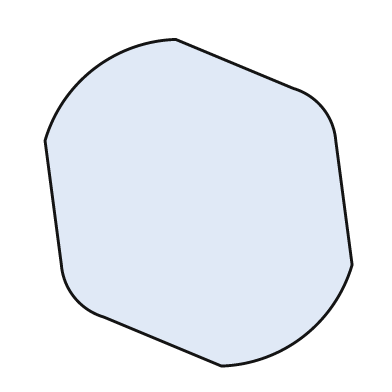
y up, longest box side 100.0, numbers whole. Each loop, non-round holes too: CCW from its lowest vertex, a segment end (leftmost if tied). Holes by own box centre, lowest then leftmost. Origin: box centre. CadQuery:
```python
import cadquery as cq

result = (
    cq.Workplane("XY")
    .moveTo(7.0, -50.0)
    .threePointArc((32.0, -41.0), (47.0, -19.0))
    .lineTo(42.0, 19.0)
    .threePointArc((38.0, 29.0), (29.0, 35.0))
    .lineTo(-7.0, 50.0)
    .threePointArc((-32.0, 41.0), (-47.0, 19.0))
    .lineTo(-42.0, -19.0)
    .threePointArc((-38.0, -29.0), (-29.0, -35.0))
    .close()
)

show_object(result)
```